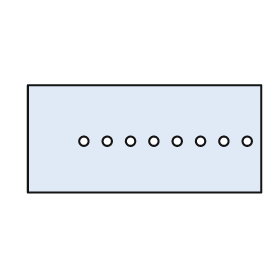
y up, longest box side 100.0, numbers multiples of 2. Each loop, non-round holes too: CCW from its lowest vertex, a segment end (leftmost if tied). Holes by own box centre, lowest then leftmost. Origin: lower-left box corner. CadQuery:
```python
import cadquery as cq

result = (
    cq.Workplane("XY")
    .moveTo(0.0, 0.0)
    .lineTo(100.0, 0.0)
    .lineTo(100.0, 46.0)
    .lineTo(0.0, 46.0)
    .close()
    .moveTo(24.0, 22.0)
    .circle(2.0)
    .moveTo(34.0, 22.0)
    .circle(2.0)
    .moveTo(44.0, 22.0)
    .circle(2.0)
    .moveTo(54.0, 22.0)
    .circle(2.0)
    .moveTo(64.0, 22.0)
    .circle(2.0)
    .moveTo(74.0, 22.0)
    .circle(2.0)
    .moveTo(84.0, 22.0)
    .circle(2.0)
    .moveTo(94.0, 22.0)
    .circle(2.0)
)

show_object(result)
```